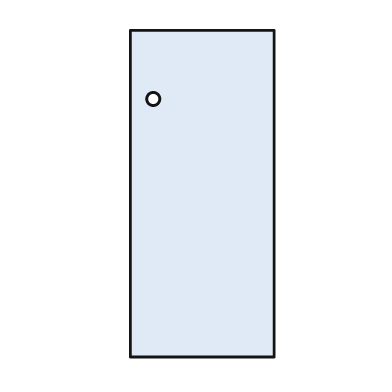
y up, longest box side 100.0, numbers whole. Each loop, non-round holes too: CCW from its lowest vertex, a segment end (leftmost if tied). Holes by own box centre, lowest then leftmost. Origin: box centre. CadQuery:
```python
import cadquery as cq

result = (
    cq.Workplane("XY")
    .moveTo(-22.0, -50.0)
    .lineTo(22.0, -50.0)
    .lineTo(22.0, 50.0)
    .lineTo(-22.0, 50.0)
    .close()
    .moveTo(-15.0, 29.0)
    .circle(2.0)
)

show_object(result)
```